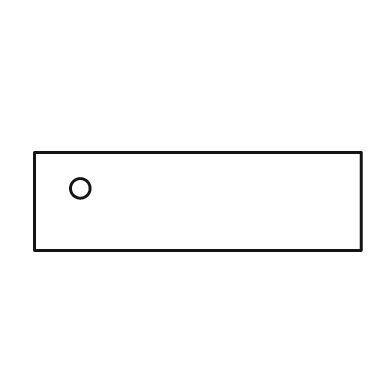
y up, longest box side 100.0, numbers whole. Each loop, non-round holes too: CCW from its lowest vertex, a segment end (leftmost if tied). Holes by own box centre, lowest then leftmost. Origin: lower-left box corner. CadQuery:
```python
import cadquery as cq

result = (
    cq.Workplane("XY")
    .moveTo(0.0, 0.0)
    .lineTo(100.0, 0.0)
    .lineTo(100.0, 30.0)
    .lineTo(0.0, 30.0)
    .close()
    .moveTo(14.0, 19.0)
    .circle(3.0)
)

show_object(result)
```